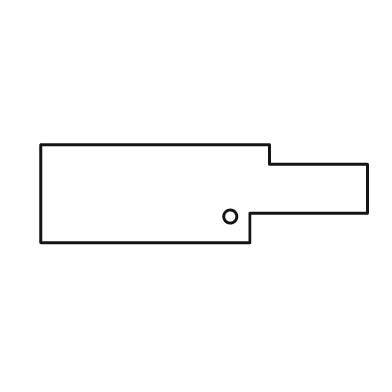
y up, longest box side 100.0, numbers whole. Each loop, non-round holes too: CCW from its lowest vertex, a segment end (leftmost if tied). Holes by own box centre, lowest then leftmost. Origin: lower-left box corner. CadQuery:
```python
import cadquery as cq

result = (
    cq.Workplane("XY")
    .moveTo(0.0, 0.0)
    .lineTo(64.0, 0.0)
    .lineTo(64.0, 9.0)
    .lineTo(100.0, 9.0)
    .lineTo(100.0, 24.0)
    .lineTo(70.0, 24.0)
    .lineTo(70.0, 30.0)
    .lineTo(0.0, 30.0)
    .close()
    .moveTo(58.0, 8.0)
    .circle(2.0)
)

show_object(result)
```